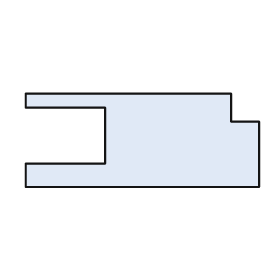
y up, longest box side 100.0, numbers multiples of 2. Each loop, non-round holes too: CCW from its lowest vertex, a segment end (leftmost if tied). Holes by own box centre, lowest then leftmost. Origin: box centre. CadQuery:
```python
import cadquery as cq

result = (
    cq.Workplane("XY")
    .moveTo(-50.0, -20.0)
    .lineTo(50.0, -20.0)
    .lineTo(50.0, 8.0)
    .lineTo(38.0, 8.0)
    .lineTo(38.0, 20.0)
    .lineTo(-50.0, 20.0)
    .lineTo(-50.0, 14.0)
    .lineTo(-16.0, 14.0)
    .lineTo(-16.0, -10.0)
    .lineTo(-50.0, -10.0)
    .close()
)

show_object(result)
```